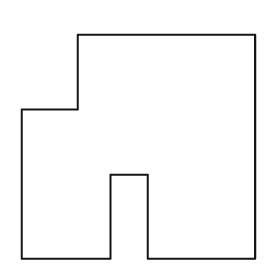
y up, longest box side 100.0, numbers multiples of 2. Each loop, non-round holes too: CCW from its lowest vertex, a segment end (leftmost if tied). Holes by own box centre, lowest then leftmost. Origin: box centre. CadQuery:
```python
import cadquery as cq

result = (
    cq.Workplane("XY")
    .moveTo(-50.0, -48.0)
    .lineTo(-12.0, -48.0)
    .lineTo(-12.0, -12.0)
    .lineTo(4.0, -12.0)
    .lineTo(4.0, -48.0)
    .lineTo(50.0, -48.0)
    .lineTo(50.0, 48.0)
    .lineTo(-26.0, 48.0)
    .lineTo(-26.0, 16.0)
    .lineTo(-50.0, 16.0)
    .close()
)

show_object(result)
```